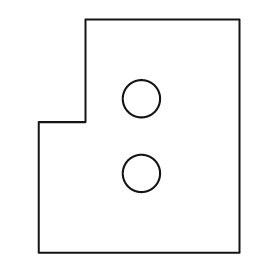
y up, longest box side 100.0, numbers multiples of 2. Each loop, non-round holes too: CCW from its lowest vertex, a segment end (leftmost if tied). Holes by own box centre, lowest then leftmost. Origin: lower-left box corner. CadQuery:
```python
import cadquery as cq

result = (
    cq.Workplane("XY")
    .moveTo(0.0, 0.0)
    .lineTo(86.0, 0.0)
    .lineTo(86.0, 100.0)
    .lineTo(20.0, 100.0)
    .lineTo(20.0, 56.0)
    .lineTo(0.0, 56.0)
    .close()
    .moveTo(44.0, 34.0)
    .circle(8.0)
    .moveTo(44.0, 66.0)
    .circle(8.0)
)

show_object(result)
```